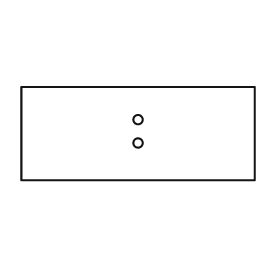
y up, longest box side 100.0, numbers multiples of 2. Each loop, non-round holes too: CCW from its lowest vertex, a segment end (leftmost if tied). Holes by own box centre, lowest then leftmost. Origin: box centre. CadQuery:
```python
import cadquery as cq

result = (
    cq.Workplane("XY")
    .moveTo(-50.0, -20.0)
    .lineTo(50.0, -20.0)
    .lineTo(50.0, 20.0)
    .lineTo(-50.0, 20.0)
    .close()
    .moveTo(0.0, -4.0)
    .circle(2.0)
    .moveTo(0.0, 6.0)
    .circle(2.0)
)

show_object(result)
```